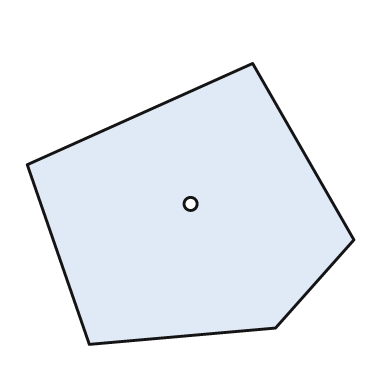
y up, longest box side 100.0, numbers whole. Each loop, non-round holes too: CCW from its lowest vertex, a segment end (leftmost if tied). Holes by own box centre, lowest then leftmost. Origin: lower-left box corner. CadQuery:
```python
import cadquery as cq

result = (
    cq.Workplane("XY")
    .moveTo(19.0, 0.0)
    .lineTo(76.0, 5.0)
    .lineTo(100.0, 32.0)
    .lineTo(69.0, 86.0)
    .lineTo(0.0, 55.0)
    .close()
    .moveTo(50.0, 43.0)
    .circle(2.0)
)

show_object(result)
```